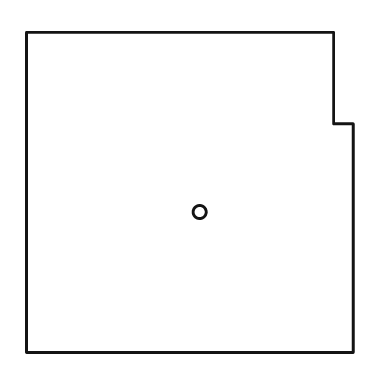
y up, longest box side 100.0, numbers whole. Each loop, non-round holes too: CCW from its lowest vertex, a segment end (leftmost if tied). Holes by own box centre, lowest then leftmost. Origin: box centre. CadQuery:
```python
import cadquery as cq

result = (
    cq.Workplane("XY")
    .moveTo(-50.0, -49.0)
    .lineTo(50.0, -49.0)
    .lineTo(50.0, 21.0)
    .lineTo(44.0, 21.0)
    .lineTo(44.0, 49.0)
    .lineTo(-50.0, 49.0)
    .close()
    .moveTo(3.0, -6.0)
    .circle(2.0)
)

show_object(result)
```